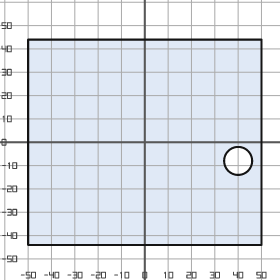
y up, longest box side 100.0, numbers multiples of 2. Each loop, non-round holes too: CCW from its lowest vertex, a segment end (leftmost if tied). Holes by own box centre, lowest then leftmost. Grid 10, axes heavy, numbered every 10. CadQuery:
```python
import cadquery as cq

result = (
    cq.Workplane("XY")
    .moveTo(-50.0, -44.0)
    .lineTo(50.0, -44.0)
    .lineTo(50.0, 44.0)
    .lineTo(-50.0, 44.0)
    .close()
    .moveTo(40.0, -8.0)
    .circle(6.0)
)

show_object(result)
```